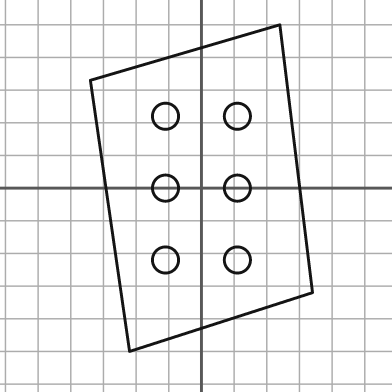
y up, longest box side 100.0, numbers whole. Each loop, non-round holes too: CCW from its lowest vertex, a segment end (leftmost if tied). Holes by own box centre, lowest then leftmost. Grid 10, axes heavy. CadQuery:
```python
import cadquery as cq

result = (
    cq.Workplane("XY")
    .moveTo(-22.0, -50.0)
    .lineTo(34.0, -32.0)
    .lineTo(24.0, 50.0)
    .lineTo(-34.0, 33.0)
    .close()
    .moveTo(-11.0, -22.0)
    .circle(4.0)
    .moveTo(11.0, -22.0)
    .circle(4.0)
    .moveTo(-11.0, 0.0)
    .circle(4.0)
    .moveTo(11.0, 0.0)
    .circle(4.0)
    .moveTo(-11.0, 22.0)
    .circle(4.0)
    .moveTo(11.0, 22.0)
    .circle(4.0)
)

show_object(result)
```